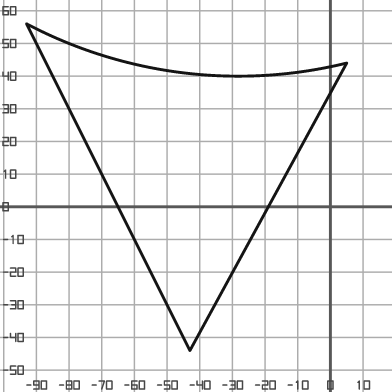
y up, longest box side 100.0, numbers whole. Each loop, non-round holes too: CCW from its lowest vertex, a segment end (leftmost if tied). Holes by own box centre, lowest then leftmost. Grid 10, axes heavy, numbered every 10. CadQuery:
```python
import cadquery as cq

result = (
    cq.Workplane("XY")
    .moveTo(-43.0, -44.0)
    .lineTo(5.0, 44.0)
    .threePointArc((-45.0, 41.0), (-93.0, 56.0))
    .close()
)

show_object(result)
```